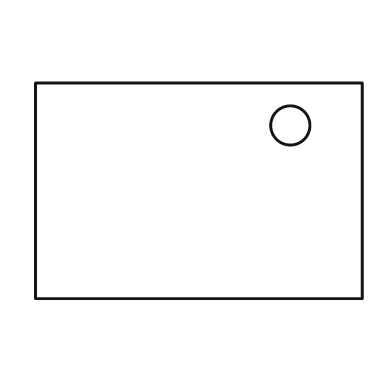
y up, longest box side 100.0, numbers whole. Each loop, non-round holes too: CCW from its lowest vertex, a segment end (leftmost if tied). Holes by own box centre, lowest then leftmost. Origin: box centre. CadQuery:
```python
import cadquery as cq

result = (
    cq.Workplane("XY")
    .moveTo(-50.0, -33.0)
    .lineTo(50.0, -33.0)
    .lineTo(50.0, 33.0)
    .lineTo(-50.0, 33.0)
    .close()
    .moveTo(28.0, 20.0)
    .circle(6.0)
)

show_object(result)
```